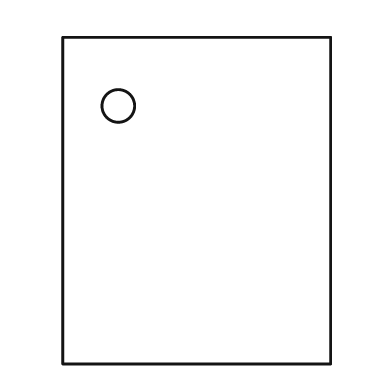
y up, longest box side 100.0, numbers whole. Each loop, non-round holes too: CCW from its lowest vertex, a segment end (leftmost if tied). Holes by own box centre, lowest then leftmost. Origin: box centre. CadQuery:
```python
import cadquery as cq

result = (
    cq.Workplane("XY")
    .moveTo(-41.0, -50.0)
    .lineTo(41.0, -50.0)
    .lineTo(41.0, 50.0)
    .lineTo(-41.0, 50.0)
    .close()
    .moveTo(-24.0, 29.0)
    .circle(5.0)
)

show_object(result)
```